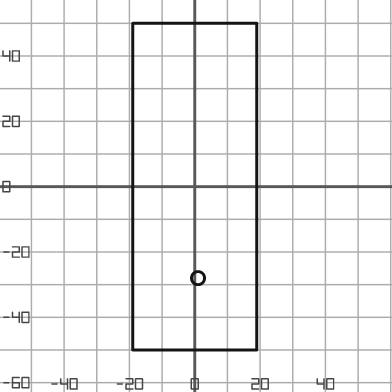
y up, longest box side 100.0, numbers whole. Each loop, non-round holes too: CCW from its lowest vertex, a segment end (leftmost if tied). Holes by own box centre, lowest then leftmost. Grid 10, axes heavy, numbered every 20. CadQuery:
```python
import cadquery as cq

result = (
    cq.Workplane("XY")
    .moveTo(-19.0, -50.0)
    .lineTo(19.0, -50.0)
    .lineTo(19.0, 50.0)
    .lineTo(-19.0, 50.0)
    .close()
    .moveTo(1.0, -28.0)
    .circle(2.0)
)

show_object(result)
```